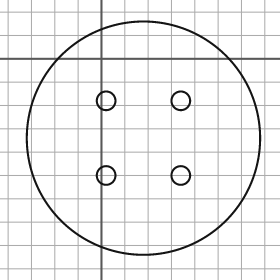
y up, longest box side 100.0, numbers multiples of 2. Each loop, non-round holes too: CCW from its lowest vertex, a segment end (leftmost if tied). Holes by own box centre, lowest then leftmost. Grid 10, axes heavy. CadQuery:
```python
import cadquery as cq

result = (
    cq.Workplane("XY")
    .moveTo(18.0, -34.0)
    .circle(50.0)
    .moveTo(2.0, -50.0)
    .circle(4.0)
    .moveTo(34.0, -50.0)
    .circle(4.0)
    .moveTo(2.0, -18.0)
    .circle(4.0)
    .moveTo(34.0, -18.0)
    .circle(4.0)
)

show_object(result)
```